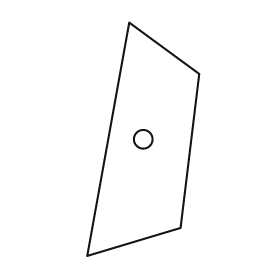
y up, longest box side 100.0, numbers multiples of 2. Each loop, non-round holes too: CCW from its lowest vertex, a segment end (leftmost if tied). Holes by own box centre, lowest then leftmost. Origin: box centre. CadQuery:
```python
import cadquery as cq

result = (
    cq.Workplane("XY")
    .moveTo(-24.0, -50.0)
    .lineTo(16.0, -38.0)
    .lineTo(24.0, 28.0)
    .lineTo(-6.0, 50.0)
    .close()
    .moveTo(0.0, 0.0)
    .circle(4.0)
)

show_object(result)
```